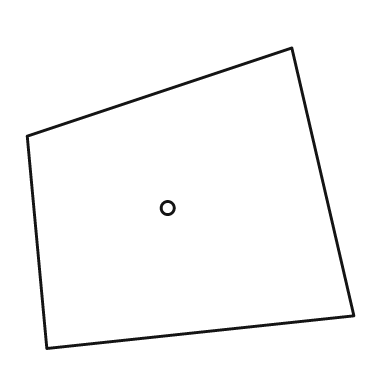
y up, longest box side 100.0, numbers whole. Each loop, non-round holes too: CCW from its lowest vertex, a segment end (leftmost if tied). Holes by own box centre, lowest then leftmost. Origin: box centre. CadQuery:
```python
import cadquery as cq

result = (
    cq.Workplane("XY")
    .moveTo(-44.0, -46.0)
    .lineTo(50.0, -36.0)
    .lineTo(31.0, 46.0)
    .lineTo(-50.0, 19.0)
    .close()
    .moveTo(-7.0, -3.0)
    .circle(2.0)
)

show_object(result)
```